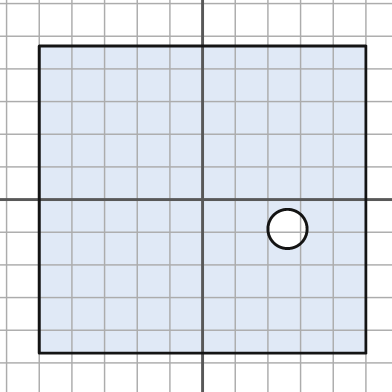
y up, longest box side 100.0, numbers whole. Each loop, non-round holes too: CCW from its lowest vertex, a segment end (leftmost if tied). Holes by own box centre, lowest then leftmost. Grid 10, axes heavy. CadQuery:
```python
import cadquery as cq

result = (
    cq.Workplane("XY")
    .moveTo(-50.0, -47.0)
    .lineTo(50.0, -47.0)
    .lineTo(50.0, 47.0)
    .lineTo(-50.0, 47.0)
    .close()
    .moveTo(26.0, -9.0)
    .circle(6.0)
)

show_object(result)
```